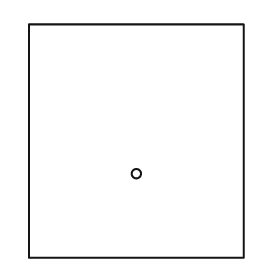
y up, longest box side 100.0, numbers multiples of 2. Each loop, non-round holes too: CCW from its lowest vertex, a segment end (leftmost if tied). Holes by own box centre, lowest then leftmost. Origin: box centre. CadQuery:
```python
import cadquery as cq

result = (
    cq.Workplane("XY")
    .moveTo(-46.0, -50.0)
    .lineTo(46.0, -50.0)
    .lineTo(46.0, 50.0)
    .lineTo(-46.0, 50.0)
    .close()
    .moveTo(0.0, -14.0)
    .circle(2.0)
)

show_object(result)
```